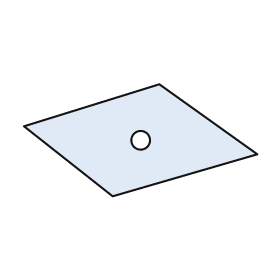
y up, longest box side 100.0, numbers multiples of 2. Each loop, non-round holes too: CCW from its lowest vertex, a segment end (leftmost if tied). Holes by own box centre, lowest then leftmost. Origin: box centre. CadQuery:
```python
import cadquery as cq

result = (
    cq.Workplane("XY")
    .moveTo(-12.0, -24.0)
    .lineTo(50.0, -6.0)
    .lineTo(8.0, 24.0)
    .lineTo(-50.0, 6.0)
    .close()
    .moveTo(0.0, 0.0)
    .circle(4.0)
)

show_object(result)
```